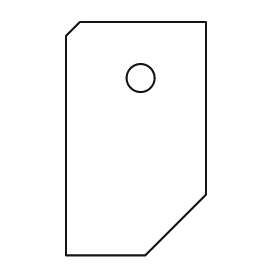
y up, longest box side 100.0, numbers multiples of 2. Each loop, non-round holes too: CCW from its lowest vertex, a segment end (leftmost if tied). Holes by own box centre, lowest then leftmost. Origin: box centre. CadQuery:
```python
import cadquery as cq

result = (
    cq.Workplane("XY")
    .moveTo(-30.0, -50.0)
    .lineTo(4.0, -50.0)
    .lineTo(30.0, -24.0)
    .lineTo(30.0, 50.0)
    .lineTo(-24.0, 50.0)
    .lineTo(-30.0, 44.0)
    .close()
    .moveTo(2.0, 26.0)
    .circle(6.0)
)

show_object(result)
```